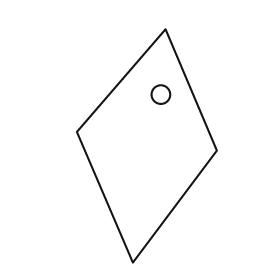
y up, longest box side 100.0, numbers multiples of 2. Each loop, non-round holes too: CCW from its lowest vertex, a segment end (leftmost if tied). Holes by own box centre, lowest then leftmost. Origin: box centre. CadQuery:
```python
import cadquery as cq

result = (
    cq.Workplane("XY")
    .moveTo(-6.0, -50.0)
    .lineTo(30.0, -2.0)
    .lineTo(8.0, 50.0)
    .lineTo(-30.0, 6.0)
    .close()
    .moveTo(6.0, 22.0)
    .circle(4.0)
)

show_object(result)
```